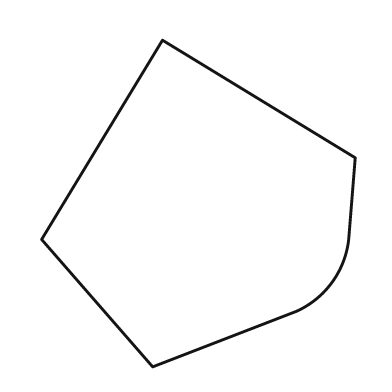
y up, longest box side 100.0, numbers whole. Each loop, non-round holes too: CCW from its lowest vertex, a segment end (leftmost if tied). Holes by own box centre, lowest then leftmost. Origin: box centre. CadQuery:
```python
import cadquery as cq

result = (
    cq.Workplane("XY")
    .moveTo(-14.0, -50.0)
    .lineTo(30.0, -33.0)
    .threePointArc((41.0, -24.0), (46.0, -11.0))
    .lineTo(48.0, 14.0)
    .lineTo(-11.0, 50.0)
    .lineTo(-48.0, -11.0)
    .close()
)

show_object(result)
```